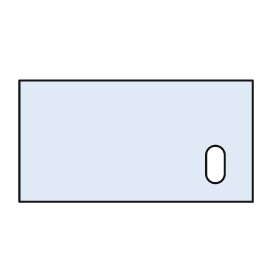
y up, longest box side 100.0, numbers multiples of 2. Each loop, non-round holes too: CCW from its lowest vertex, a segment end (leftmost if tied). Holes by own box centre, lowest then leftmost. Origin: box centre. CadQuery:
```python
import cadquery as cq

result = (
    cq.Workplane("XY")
    .moveTo(-50.0, -26.0)
    .lineTo(50.0, -26.0)
    .lineTo(50.0, 26.0)
    .lineTo(-50.0, 26.0)
    .close()
    .moveTo(30.0, -14.0)
    .threePointArc((34.0, -18.0), (38.0, -14.0))
    .lineTo(38.0, -6.0)
    .threePointArc((34.0, -2.0), (30.0, -6.0))
    .close()
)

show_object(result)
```